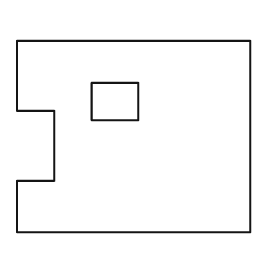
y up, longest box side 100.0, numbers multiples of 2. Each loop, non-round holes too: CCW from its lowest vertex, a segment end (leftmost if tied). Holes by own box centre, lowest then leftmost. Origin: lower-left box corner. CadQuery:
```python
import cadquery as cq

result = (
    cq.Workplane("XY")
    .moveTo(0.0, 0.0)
    .lineTo(100.0, 0.0)
    .lineTo(100.0, 82.0)
    .lineTo(0.0, 82.0)
    .lineTo(0.0, 52.0)
    .lineTo(16.0, 52.0)
    .lineTo(16.0, 22.0)
    .lineTo(0.0, 22.0)
    .close()
    .moveTo(32.0, 48.0)
    .lineTo(52.0, 48.0)
    .lineTo(52.0, 64.0)
    .lineTo(32.0, 64.0)
    .close()
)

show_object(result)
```